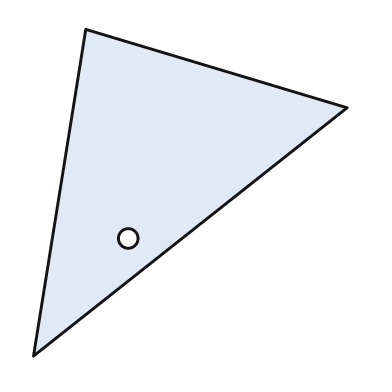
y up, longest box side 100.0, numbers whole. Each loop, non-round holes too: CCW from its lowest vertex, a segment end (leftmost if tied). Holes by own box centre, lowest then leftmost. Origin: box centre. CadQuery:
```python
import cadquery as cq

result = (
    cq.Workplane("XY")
    .moveTo(-48.0, -50.0)
    .lineTo(48.0, 26.0)
    .lineTo(-32.0, 50.0)
    .close()
    .moveTo(-19.0, -14.0)
    .circle(3.0)
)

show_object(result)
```